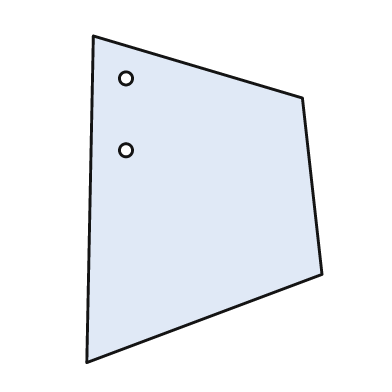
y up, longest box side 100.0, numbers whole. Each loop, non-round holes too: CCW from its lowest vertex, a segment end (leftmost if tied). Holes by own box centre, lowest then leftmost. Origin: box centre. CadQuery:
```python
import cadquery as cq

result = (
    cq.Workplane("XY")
    .moveTo(-36.0, -50.0)
    .lineTo(36.0, -23.0)
    .lineTo(30.0, 31.0)
    .lineTo(-34.0, 50.0)
    .close()
    .moveTo(-24.0, 15.0)
    .circle(2.0)
    .moveTo(-24.0, 37.0)
    .circle(2.0)
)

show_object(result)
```